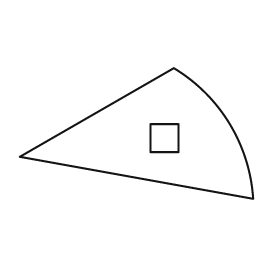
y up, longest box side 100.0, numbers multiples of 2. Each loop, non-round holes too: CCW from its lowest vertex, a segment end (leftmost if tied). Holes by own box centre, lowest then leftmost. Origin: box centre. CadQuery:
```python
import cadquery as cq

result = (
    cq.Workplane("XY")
    .moveTo(50.0, -28.0)
    .threePointArc((40.0, 4.0), (16.0, 28.0))
    .lineTo(-50.0, -10.0)
    .close()
    .moveTo(6.0, -8.0)
    .lineTo(18.0, -8.0)
    .lineTo(18.0, 4.0)
    .lineTo(6.0, 4.0)
    .close()
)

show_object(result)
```